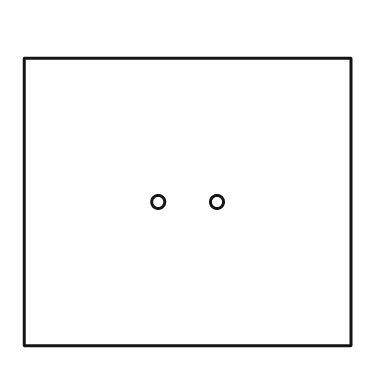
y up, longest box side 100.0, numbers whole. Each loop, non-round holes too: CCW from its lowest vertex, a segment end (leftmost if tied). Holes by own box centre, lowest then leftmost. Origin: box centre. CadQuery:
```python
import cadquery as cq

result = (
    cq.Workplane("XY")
    .moveTo(-50.0, -44.0)
    .lineTo(50.0, -44.0)
    .lineTo(50.0, 44.0)
    .lineTo(-50.0, 44.0)
    .close()
    .moveTo(-9.0, 0.0)
    .circle(2.0)
    .moveTo(9.0, 0.0)
    .circle(2.0)
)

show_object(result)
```